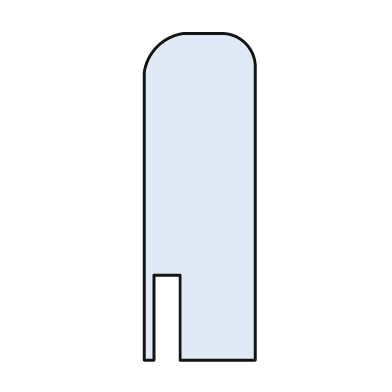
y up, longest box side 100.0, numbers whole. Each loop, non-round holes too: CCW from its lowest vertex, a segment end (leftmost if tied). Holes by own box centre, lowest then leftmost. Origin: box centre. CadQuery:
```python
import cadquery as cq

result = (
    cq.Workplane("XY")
    .moveTo(-17.0, -50.0)
    .lineTo(-14.0, -50.0)
    .lineTo(-14.0, -24.0)
    .lineTo(-6.0, -24.0)
    .lineTo(-6.0, -50.0)
    .lineTo(17.0, -50.0)
    .lineTo(17.0, 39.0)
    .threePointArc((14.0, 47.0), (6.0, 50.0))
    .lineTo(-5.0, 50.0)
    .threePointArc((-13.0, 46.0), (-17.0, 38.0))
    .close()
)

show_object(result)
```